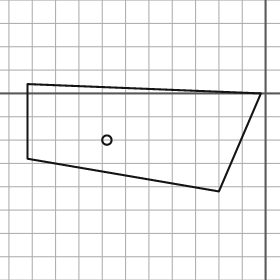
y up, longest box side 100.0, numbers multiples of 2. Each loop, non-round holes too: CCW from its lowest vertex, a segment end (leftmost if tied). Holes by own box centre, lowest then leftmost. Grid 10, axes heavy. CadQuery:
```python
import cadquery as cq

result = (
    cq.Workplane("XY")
    .moveTo(-20.0, -42.0)
    .lineTo(-2.0, 0.0)
    .lineTo(-102.0, 4.0)
    .lineTo(-102.0, -28.0)
    .close()
    .moveTo(-68.0, -20.0)
    .circle(2.0)
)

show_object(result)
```